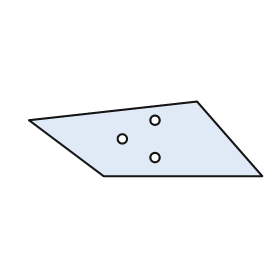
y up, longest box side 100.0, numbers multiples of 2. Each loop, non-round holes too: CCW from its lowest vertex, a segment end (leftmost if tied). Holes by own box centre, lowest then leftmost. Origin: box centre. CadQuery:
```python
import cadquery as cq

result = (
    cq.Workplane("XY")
    .moveTo(-18.0, -16.0)
    .lineTo(50.0, -16.0)
    .lineTo(22.0, 16.0)
    .lineTo(-50.0, 8.0)
    .close()
    .moveTo(4.0, -8.0)
    .circle(2.0)
    .moveTo(-10.0, 0.0)
    .circle(2.0)
    .moveTo(4.0, 8.0)
    .circle(2.0)
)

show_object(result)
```